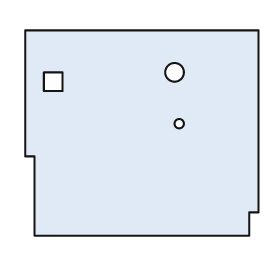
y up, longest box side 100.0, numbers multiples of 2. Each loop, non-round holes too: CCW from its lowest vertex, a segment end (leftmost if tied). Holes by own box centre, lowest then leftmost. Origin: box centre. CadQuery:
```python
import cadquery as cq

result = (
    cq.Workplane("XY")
    .moveTo(-46.0, -44.0)
    .lineTo(46.0, -44.0)
    .lineTo(46.0, -34.0)
    .lineTo(50.0, -34.0)
    .lineTo(50.0, 44.0)
    .lineTo(-50.0, 44.0)
    .lineTo(-50.0, -10.0)
    .lineTo(-46.0, -10.0)
    .close()
    .moveTo(16.0, 4.0)
    .circle(2.0)
    .moveTo(-42.0, 18.0)
    .lineTo(-34.0, 18.0)
    .lineTo(-34.0, 26.0)
    .lineTo(-42.0, 26.0)
    .close()
    .moveTo(14.0, 26.0)
    .circle(4.0)
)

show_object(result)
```